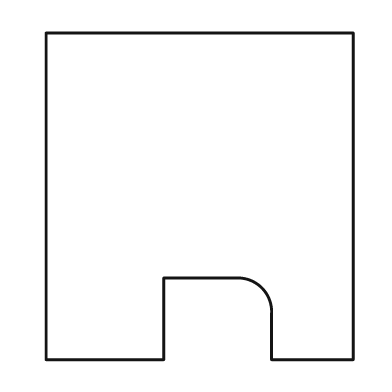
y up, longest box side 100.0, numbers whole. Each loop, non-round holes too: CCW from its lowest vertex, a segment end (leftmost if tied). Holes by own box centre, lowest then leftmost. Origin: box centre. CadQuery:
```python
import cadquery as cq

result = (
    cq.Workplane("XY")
    .moveTo(-47.0, -50.0)
    .lineTo(-11.0, -50.0)
    .lineTo(-11.0, -25.0)
    .lineTo(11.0, -25.0)
    .threePointArc((19.0, -28.0), (22.0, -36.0))
    .lineTo(22.0, -50.0)
    .lineTo(47.0, -50.0)
    .lineTo(47.0, 50.0)
    .lineTo(-47.0, 50.0)
    .close()
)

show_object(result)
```